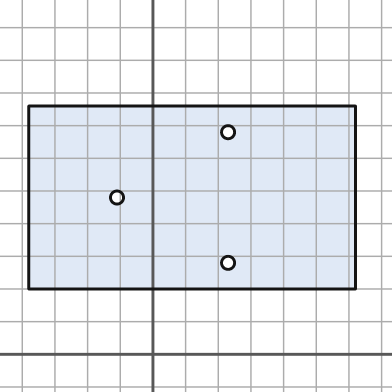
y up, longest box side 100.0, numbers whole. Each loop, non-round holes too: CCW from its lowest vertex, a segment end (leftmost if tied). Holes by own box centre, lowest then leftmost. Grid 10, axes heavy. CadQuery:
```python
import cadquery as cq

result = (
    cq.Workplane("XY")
    .moveTo(-38.0, 20.0)
    .lineTo(62.0, 20.0)
    .lineTo(62.0, 76.0)
    .lineTo(-38.0, 76.0)
    .close()
    .moveTo(23.0, 28.0)
    .circle(2.0)
    .moveTo(-11.0, 48.0)
    .circle(2.0)
    .moveTo(23.0, 68.0)
    .circle(2.0)
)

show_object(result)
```